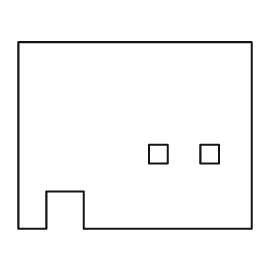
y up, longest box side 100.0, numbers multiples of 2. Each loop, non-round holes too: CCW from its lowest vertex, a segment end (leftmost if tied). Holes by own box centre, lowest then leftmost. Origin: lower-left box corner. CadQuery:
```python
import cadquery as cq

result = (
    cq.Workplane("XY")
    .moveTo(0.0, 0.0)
    .lineTo(12.0, 0.0)
    .lineTo(12.0, 16.0)
    .lineTo(28.0, 16.0)
    .lineTo(28.0, 0.0)
    .lineTo(100.0, 0.0)
    .lineTo(100.0, 80.0)
    .lineTo(0.0, 80.0)
    .close()
    .moveTo(56.0, 28.0)
    .lineTo(64.0, 28.0)
    .lineTo(64.0, 36.0)
    .lineTo(56.0, 36.0)
    .close()
    .moveTo(78.0, 28.0)
    .lineTo(86.0, 28.0)
    .lineTo(86.0, 36.0)
    .lineTo(78.0, 36.0)
    .close()
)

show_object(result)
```